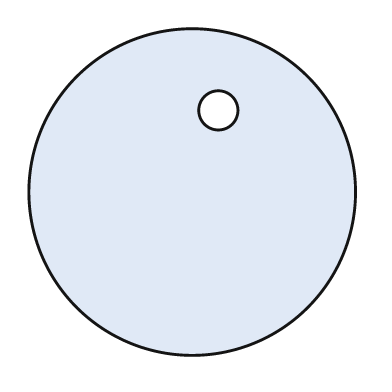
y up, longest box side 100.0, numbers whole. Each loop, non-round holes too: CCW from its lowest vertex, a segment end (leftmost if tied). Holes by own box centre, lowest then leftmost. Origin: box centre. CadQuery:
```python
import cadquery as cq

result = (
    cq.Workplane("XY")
    .moveTo(0.0, 0.0)
    .circle(50.0)
    .moveTo(8.0, 25.0)
    .circle(6.0)
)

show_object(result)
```